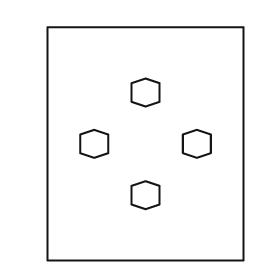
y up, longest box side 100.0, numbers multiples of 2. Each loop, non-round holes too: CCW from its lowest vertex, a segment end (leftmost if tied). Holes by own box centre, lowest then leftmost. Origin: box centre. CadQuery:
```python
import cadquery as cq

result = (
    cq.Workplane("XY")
    .moveTo(-42.0, -50.0)
    .lineTo(42.0, -50.0)
    .lineTo(42.0, 50.0)
    .lineTo(-42.0, 50.0)
    .close()
    .moveTo(0.0, -28.0)
    .lineTo(6.0, -26.0)
    .lineTo(6.0, -18.0)
    .lineTo(0.0, -16.0)
    .lineTo(-6.0, -18.0)
    .lineTo(-6.0, -26.0)
    .close()
    .moveTo(-22.0, -6.0)
    .lineTo(-16.0, -4.0)
    .lineTo(-16.0, 4.0)
    .lineTo(-22.0, 6.0)
    .lineTo(-28.0, 4.0)
    .lineTo(-28.0, -4.0)
    .close()
    .moveTo(22.0, -6.0)
    .lineTo(28.0, -4.0)
    .lineTo(28.0, 4.0)
    .lineTo(22.0, 6.0)
    .lineTo(16.0, 4.0)
    .lineTo(16.0, -4.0)
    .close()
    .moveTo(0.0, 16.0)
    .lineTo(6.0, 18.0)
    .lineTo(6.0, 26.0)
    .lineTo(0.0, 28.0)
    .lineTo(-6.0, 26.0)
    .lineTo(-6.0, 18.0)
    .close()
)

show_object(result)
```